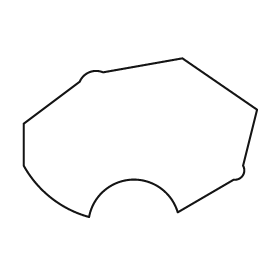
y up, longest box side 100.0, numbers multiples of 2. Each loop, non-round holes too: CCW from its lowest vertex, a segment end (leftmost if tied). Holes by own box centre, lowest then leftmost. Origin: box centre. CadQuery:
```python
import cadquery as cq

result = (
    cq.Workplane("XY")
    .moveTo(-22.0, -34.0)
    .threePointArc((-4.0, -18.0), (16.0, -32.0))
    .lineTo(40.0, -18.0)
    .threePointArc((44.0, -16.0), (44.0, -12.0))
    .lineTo(50.0, 12.0)
    .lineTo(18.0, 34.0)
    .lineTo(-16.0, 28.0)
    .threePointArc((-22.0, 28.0), (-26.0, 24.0))
    .lineTo(-50.0, 6.0)
    .lineTo(-50.0, -12.0)
    .threePointArc((-38.0, -26.0), (-22.0, -34.0))
    .close()
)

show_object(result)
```